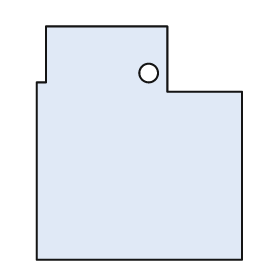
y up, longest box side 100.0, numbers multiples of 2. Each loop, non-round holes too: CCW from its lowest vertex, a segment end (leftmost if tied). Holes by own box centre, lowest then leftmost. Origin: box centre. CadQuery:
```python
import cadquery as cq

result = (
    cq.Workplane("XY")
    .moveTo(-44.0, -50.0)
    .lineTo(44.0, -50.0)
    .lineTo(44.0, 22.0)
    .lineTo(12.0, 22.0)
    .lineTo(12.0, 50.0)
    .lineTo(-40.0, 50.0)
    .lineTo(-40.0, 26.0)
    .lineTo(-44.0, 26.0)
    .close()
    .moveTo(4.0, 30.0)
    .circle(4.0)
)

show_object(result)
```